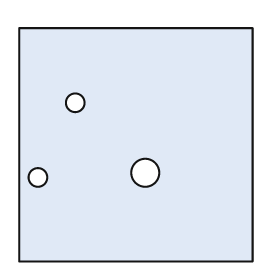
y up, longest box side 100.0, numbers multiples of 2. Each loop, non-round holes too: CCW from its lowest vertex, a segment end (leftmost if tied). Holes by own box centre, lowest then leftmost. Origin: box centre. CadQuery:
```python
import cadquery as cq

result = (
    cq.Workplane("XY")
    .moveTo(-50.0, -50.0)
    .lineTo(50.0, -50.0)
    .lineTo(50.0, 50.0)
    .lineTo(-50.0, 50.0)
    .close()
    .moveTo(-42.0, -14.0)
    .circle(4.0)
    .moveTo(4.0, -12.0)
    .circle(6.0)
    .moveTo(-26.0, 18.0)
    .circle(4.0)
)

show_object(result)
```